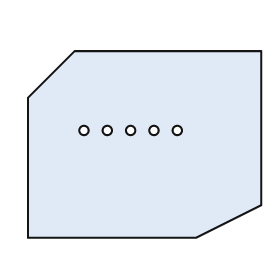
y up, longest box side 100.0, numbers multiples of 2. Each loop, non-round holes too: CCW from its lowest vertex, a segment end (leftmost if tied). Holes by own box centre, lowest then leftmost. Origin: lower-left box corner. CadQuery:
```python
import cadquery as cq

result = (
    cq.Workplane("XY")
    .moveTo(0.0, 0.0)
    .lineTo(72.0, 0.0)
    .lineTo(100.0, 14.0)
    .lineTo(100.0, 80.0)
    .lineTo(20.0, 80.0)
    .lineTo(0.0, 60.0)
    .close()
    .moveTo(24.0, 46.0)
    .circle(2.0)
    .moveTo(34.0, 46.0)
    .circle(2.0)
    .moveTo(44.0, 46.0)
    .circle(2.0)
    .moveTo(54.0, 46.0)
    .circle(2.0)
    .moveTo(64.0, 46.0)
    .circle(2.0)
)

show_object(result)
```